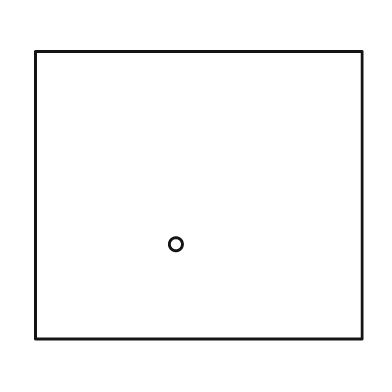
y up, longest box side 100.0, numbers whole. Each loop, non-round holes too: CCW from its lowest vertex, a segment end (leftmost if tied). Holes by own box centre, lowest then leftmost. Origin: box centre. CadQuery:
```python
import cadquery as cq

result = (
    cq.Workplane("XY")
    .moveTo(-50.0, -44.0)
    .lineTo(50.0, -44.0)
    .lineTo(50.0, 44.0)
    .lineTo(-50.0, 44.0)
    .close()
    .moveTo(-7.0, -15.0)
    .circle(2.0)
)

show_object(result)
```